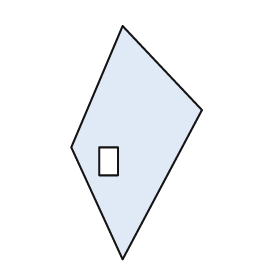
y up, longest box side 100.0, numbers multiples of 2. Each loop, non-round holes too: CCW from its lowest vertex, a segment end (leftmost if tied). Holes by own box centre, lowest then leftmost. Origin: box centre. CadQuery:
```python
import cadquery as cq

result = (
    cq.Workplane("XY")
    .moveTo(-6.0, -50.0)
    .lineTo(28.0, 14.0)
    .lineTo(-6.0, 50.0)
    .lineTo(-28.0, -2.0)
    .close()
    .moveTo(-16.0, -14.0)
    .lineTo(-8.0, -14.0)
    .lineTo(-8.0, -2.0)
    .lineTo(-16.0, -2.0)
    .close()
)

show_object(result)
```